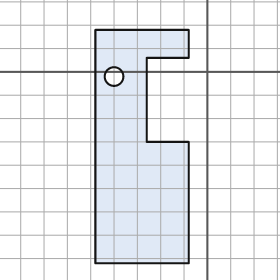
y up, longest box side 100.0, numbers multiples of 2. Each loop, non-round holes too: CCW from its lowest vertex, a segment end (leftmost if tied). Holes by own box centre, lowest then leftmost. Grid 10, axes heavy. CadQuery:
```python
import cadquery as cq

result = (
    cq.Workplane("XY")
    .moveTo(-48.0, -82.0)
    .lineTo(-8.0, -82.0)
    .lineTo(-8.0, -30.0)
    .lineTo(-26.0, -30.0)
    .lineTo(-26.0, 6.0)
    .lineTo(-8.0, 6.0)
    .lineTo(-8.0, 18.0)
    .lineTo(-48.0, 18.0)
    .close()
    .moveTo(-40.0, -2.0)
    .circle(4.0)
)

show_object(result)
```